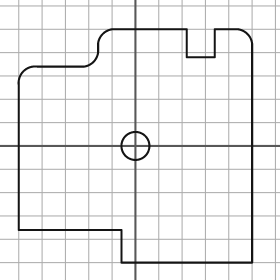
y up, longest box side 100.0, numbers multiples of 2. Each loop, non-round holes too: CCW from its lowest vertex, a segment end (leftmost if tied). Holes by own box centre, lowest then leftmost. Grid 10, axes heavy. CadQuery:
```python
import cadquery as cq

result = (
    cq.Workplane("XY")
    .moveTo(-6.0, -50.0)
    .lineTo(50.0, -50.0)
    .lineTo(50.0, 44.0)
    .threePointArc((48.0, 48.0), (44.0, 50.0))
    .lineTo(34.0, 50.0)
    .lineTo(34.0, 38.0)
    .lineTo(22.0, 38.0)
    .lineTo(22.0, 50.0)
    .lineTo(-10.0, 50.0)
    .threePointArc((-14.0, 48.0), (-16.0, 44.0))
    .lineTo(-16.0, 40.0)
    .threePointArc((-18.0, 36.0), (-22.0, 34.0))
    .lineTo(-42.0, 34.0)
    .threePointArc((-48.0, 32.0), (-50.0, 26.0))
    .lineTo(-50.0, -36.0)
    .lineTo(-6.0, -36.0)
    .close()
    .moveTo(0.0, 0.0)
    .circle(6.0)
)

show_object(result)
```